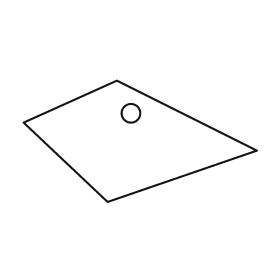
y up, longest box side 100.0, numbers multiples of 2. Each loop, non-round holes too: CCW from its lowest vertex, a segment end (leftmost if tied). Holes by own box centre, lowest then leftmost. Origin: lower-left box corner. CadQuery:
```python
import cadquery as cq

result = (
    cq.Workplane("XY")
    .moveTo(36.0, 0.0)
    .lineTo(100.0, 22.0)
    .lineTo(40.0, 52.0)
    .lineTo(0.0, 34.0)
    .close()
    .moveTo(46.0, 38.0)
    .circle(4.0)
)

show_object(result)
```